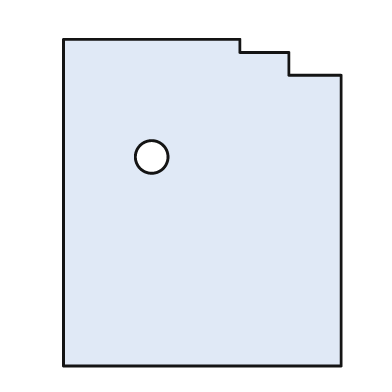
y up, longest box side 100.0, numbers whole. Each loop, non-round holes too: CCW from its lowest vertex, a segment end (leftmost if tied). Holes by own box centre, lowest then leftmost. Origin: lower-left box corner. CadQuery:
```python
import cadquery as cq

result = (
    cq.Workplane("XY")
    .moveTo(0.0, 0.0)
    .lineTo(85.0, 0.0)
    .lineTo(85.0, 89.0)
    .lineTo(69.0, 89.0)
    .lineTo(69.0, 96.0)
    .lineTo(54.0, 96.0)
    .lineTo(54.0, 100.0)
    .lineTo(0.0, 100.0)
    .close()
    .moveTo(27.0, 64.0)
    .circle(5.0)
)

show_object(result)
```